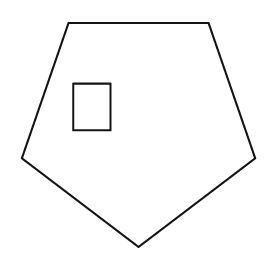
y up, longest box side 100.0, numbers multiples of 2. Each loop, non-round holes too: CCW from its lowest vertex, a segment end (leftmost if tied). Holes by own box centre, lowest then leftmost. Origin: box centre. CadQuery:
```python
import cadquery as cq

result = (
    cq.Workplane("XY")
    .moveTo(0.0, -48.0)
    .lineTo(50.0, -10.0)
    .lineTo(30.0, 48.0)
    .lineTo(-30.0, 48.0)
    .lineTo(-50.0, -10.0)
    .close()
    .moveTo(-28.0, 2.0)
    .lineTo(-12.0, 2.0)
    .lineTo(-12.0, 22.0)
    .lineTo(-28.0, 22.0)
    .close()
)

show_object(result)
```